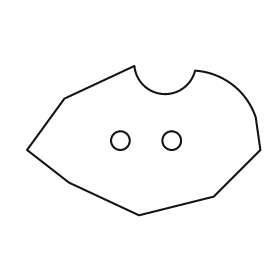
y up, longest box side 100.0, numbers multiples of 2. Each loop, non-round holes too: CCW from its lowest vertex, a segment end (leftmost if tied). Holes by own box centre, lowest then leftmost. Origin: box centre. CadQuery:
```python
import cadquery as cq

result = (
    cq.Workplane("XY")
    .moveTo(-2.0, -32.0)
    .lineTo(30.0, -24.0)
    .lineTo(50.0, -4.0)
    .lineTo(48.0, 10.0)
    .threePointArc((38.0, 24.0), (22.0, 30.0))
    .threePointArc((8.0, 20.0), (-4.0, 32.0))
    .lineTo(-34.0, 18.0)
    .lineTo(-50.0, -4.0)
    .lineTo(-32.0, -18.0)
    .close()
    .moveTo(-10.0, 0.0)
    .circle(4.0)
    .moveTo(12.0, 0.0)
    .circle(4.0)
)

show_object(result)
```